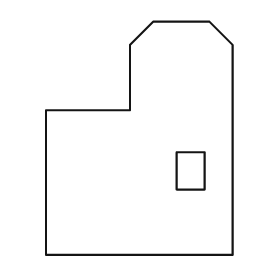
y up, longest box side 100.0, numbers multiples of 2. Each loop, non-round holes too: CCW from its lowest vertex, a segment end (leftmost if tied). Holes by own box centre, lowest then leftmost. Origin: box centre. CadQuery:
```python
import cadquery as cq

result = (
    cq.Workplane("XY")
    .moveTo(-40.0, -50.0)
    .lineTo(40.0, -50.0)
    .lineTo(40.0, 40.0)
    .lineTo(30.0, 50.0)
    .lineTo(6.0, 50.0)
    .lineTo(-4.0, 40.0)
    .lineTo(-4.0, 12.0)
    .lineTo(-40.0, 12.0)
    .close()
    .moveTo(16.0, -22.0)
    .lineTo(28.0, -22.0)
    .lineTo(28.0, -6.0)
    .lineTo(16.0, -6.0)
    .close()
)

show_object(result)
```